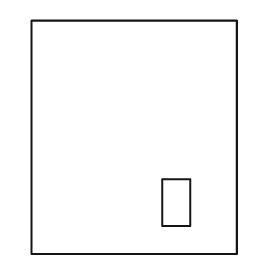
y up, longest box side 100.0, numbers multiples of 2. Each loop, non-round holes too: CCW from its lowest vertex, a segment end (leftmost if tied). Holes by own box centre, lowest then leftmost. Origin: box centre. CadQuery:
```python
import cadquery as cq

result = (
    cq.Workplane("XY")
    .moveTo(-44.0, -50.0)
    .lineTo(44.0, -50.0)
    .lineTo(44.0, 50.0)
    .lineTo(-44.0, 50.0)
    .close()
    .moveTo(12.0, -38.0)
    .lineTo(24.0, -38.0)
    .lineTo(24.0, -18.0)
    .lineTo(12.0, -18.0)
    .close()
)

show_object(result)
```